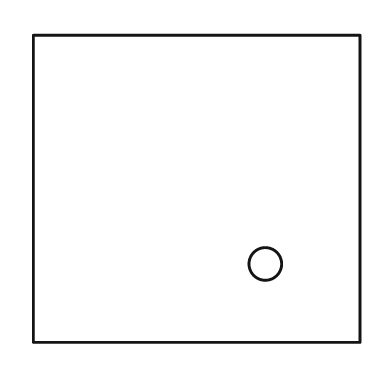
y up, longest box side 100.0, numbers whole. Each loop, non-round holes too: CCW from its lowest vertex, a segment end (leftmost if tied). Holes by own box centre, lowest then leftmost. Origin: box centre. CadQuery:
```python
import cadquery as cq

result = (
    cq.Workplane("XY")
    .moveTo(-50.0, -47.0)
    .lineTo(50.0, -47.0)
    .lineTo(50.0, 47.0)
    .lineTo(-50.0, 47.0)
    .close()
    .moveTo(21.0, -23.0)
    .circle(5.0)
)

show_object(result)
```